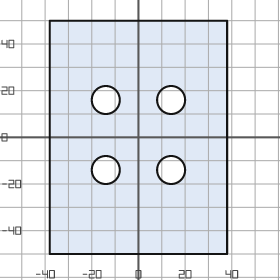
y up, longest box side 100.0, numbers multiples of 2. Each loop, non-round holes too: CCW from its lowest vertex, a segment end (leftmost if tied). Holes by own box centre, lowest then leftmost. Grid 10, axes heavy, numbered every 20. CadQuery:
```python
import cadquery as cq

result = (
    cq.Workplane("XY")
    .moveTo(-38.0, -50.0)
    .lineTo(38.0, -50.0)
    .lineTo(38.0, 50.0)
    .lineTo(-38.0, 50.0)
    .close()
    .moveTo(-14.0, -14.0)
    .circle(6.0)
    .moveTo(14.0, -14.0)
    .circle(6.0)
    .moveTo(-14.0, 16.0)
    .circle(6.0)
    .moveTo(14.0, 16.0)
    .circle(6.0)
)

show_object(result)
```